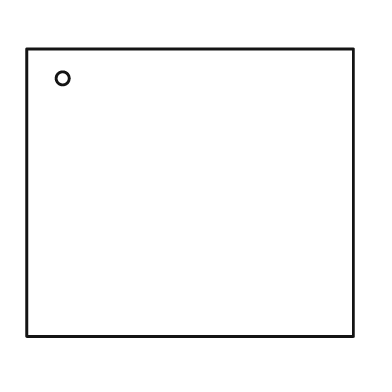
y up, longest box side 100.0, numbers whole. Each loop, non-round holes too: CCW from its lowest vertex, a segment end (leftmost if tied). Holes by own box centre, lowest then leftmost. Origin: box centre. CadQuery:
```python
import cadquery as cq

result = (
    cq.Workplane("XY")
    .moveTo(-50.0, -44.0)
    .lineTo(50.0, -44.0)
    .lineTo(50.0, 44.0)
    .lineTo(-50.0, 44.0)
    .close()
    .moveTo(-39.0, 35.0)
    .circle(2.0)
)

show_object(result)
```